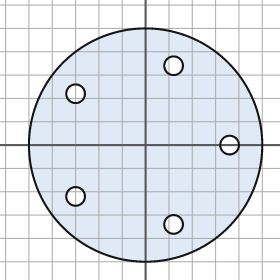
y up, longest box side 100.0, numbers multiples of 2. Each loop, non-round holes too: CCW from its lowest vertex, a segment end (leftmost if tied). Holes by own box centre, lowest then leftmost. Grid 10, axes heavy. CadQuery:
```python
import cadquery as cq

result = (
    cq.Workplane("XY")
    .moveTo(0.0, 0.0)
    .circle(50.0)
    .moveTo(12.0, -34.0)
    .circle(4.0)
    .moveTo(-30.0, -22.0)
    .circle(4.0)
    .moveTo(36.0, 0.0)
    .circle(4.0)
    .moveTo(-30.0, 22.0)
    .circle(4.0)
    .moveTo(12.0, 34.0)
    .circle(4.0)
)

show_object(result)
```